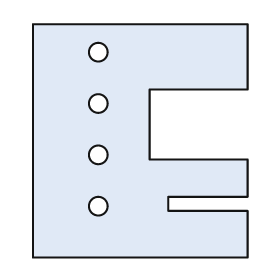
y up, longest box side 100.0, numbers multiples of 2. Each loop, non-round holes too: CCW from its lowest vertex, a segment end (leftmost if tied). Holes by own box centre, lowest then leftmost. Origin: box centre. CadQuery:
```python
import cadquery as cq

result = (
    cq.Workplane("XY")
    .moveTo(-46.0, -50.0)
    .lineTo(46.0, -50.0)
    .lineTo(46.0, -30.0)
    .lineTo(12.0, -30.0)
    .lineTo(12.0, -24.0)
    .lineTo(46.0, -24.0)
    .lineTo(46.0, -8.0)
    .lineTo(4.0, -8.0)
    .lineTo(4.0, 22.0)
    .lineTo(46.0, 22.0)
    .lineTo(46.0, 50.0)
    .lineTo(-46.0, 50.0)
    .close()
    .moveTo(-18.0, -28.0)
    .circle(4.0)
    .moveTo(-18.0, -6.0)
    .circle(4.0)
    .moveTo(-18.0, 16.0)
    .circle(4.0)
    .moveTo(-18.0, 38.0)
    .circle(4.0)
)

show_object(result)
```